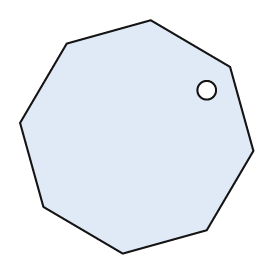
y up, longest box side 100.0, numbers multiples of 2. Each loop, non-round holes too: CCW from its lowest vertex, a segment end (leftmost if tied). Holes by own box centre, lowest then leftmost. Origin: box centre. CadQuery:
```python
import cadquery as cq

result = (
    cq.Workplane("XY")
    .moveTo(-6.0, -50.0)
    .lineTo(30.0, -40.0)
    .lineTo(50.0, -6.0)
    .lineTo(40.0, 30.0)
    .lineTo(6.0, 50.0)
    .lineTo(-30.0, 40.0)
    .lineTo(-50.0, 6.0)
    .lineTo(-40.0, -30.0)
    .close()
    .moveTo(30.0, 20.0)
    .circle(4.0)
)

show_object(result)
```